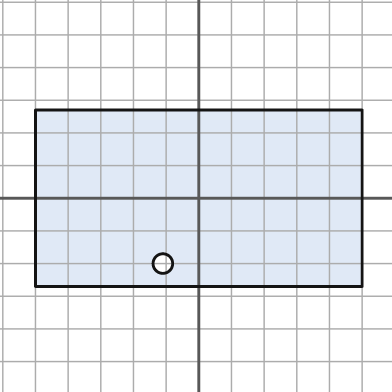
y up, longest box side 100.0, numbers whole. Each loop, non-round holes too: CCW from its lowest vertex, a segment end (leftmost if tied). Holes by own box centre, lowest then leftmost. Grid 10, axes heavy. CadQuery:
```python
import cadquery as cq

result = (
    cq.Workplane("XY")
    .moveTo(-50.0, -27.0)
    .lineTo(50.0, -27.0)
    .lineTo(50.0, 27.0)
    .lineTo(-50.0, 27.0)
    .close()
    .moveTo(-11.0, -20.0)
    .circle(3.0)
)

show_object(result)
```